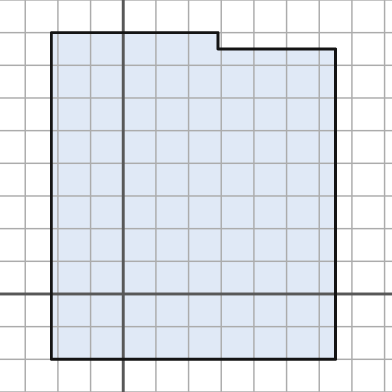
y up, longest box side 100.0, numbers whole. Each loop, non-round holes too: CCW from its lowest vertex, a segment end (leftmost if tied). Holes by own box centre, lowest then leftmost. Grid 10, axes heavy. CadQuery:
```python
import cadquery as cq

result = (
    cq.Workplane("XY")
    .moveTo(-22.0, -20.0)
    .lineTo(65.0, -20.0)
    .lineTo(65.0, 75.0)
    .lineTo(29.0, 75.0)
    .lineTo(29.0, 80.0)
    .lineTo(-22.0, 80.0)
    .close()
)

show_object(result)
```